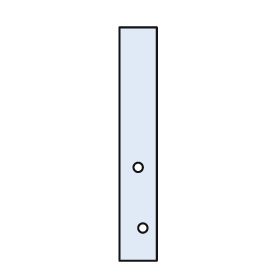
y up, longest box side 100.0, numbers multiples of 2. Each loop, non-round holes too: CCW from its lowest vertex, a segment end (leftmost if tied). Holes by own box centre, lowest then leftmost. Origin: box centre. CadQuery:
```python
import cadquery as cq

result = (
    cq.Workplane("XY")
    .moveTo(-8.0, -50.0)
    .lineTo(8.0, -50.0)
    .lineTo(8.0, 50.0)
    .lineTo(-8.0, 50.0)
    .close()
    .moveTo(2.0, -36.0)
    .circle(2.0)
    .moveTo(0.0, -10.0)
    .circle(2.0)
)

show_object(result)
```